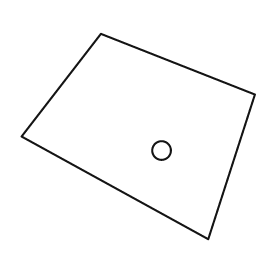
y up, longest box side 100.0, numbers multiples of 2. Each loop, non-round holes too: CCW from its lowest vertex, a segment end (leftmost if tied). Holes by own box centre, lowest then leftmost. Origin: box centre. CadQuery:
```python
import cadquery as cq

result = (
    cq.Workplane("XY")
    .moveTo(30.0, -44.0)
    .lineTo(50.0, 18.0)
    .lineTo(-16.0, 44.0)
    .lineTo(-50.0, 0.0)
    .close()
    .moveTo(10.0, -6.0)
    .circle(4.0)
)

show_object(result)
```